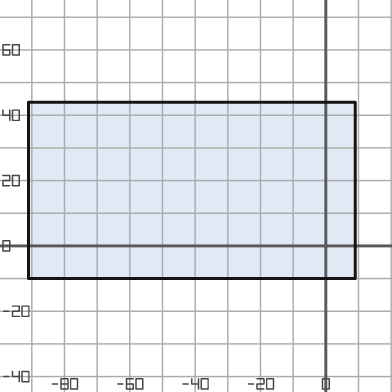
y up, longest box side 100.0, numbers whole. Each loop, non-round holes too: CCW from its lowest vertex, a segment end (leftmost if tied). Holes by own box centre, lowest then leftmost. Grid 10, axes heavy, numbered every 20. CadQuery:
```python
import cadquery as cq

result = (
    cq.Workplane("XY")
    .moveTo(-91.0, -10.0)
    .lineTo(9.0, -10.0)
    .lineTo(9.0, 44.0)
    .lineTo(-91.0, 44.0)
    .close()
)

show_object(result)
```